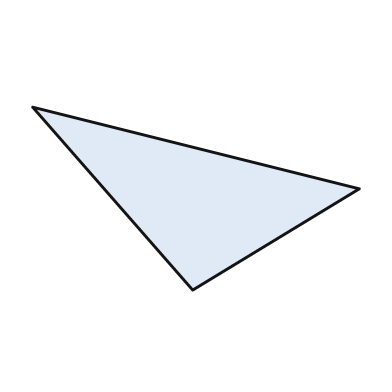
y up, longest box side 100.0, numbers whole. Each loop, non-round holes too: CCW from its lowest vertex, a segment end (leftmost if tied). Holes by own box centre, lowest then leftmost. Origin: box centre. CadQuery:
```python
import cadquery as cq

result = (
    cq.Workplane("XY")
    .moveTo(-1.0, -28.0)
    .lineTo(50.0, 3.0)
    .lineTo(-50.0, 28.0)
    .close()
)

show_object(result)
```